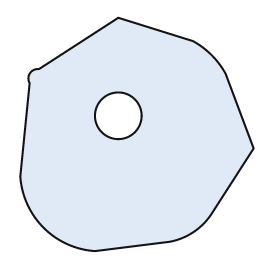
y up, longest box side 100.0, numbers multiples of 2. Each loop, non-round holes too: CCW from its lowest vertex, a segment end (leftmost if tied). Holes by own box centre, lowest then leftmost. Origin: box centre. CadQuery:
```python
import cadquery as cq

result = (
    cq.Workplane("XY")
    .moveTo(-18.0, -50.0)
    .lineTo(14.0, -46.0)
    .threePointArc((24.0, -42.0), (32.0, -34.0))
    .lineTo(50.0, -6.0)
    .lineTo(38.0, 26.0)
    .threePointArc((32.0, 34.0), (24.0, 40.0))
    .lineTo(-8.0, 50.0)
    .lineTo(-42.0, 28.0)
    .threePointArc((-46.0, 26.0), (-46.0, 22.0))
    .lineTo(-50.0, -18.0)
    .threePointArc((-40.0, -40.0), (-18.0, -50.0))
    .close()
    .moveTo(-8.0, 8.0)
    .circle(10.0)
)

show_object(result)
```